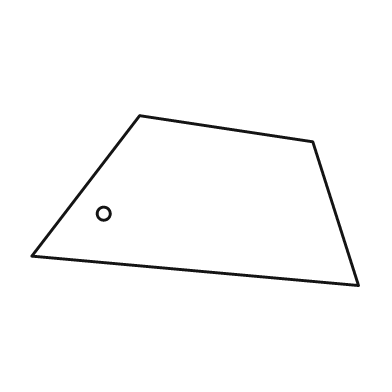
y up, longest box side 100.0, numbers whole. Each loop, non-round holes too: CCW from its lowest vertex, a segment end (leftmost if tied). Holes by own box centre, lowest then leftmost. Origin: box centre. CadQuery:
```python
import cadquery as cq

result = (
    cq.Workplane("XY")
    .moveTo(50.0, -26.0)
    .lineTo(36.0, 18.0)
    .lineTo(-17.0, 26.0)
    .lineTo(-50.0, -17.0)
    .close()
    .moveTo(-28.0, -4.0)
    .circle(2.0)
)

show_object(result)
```